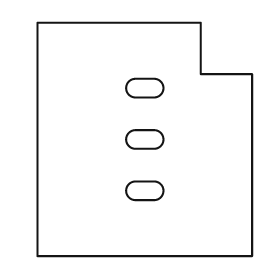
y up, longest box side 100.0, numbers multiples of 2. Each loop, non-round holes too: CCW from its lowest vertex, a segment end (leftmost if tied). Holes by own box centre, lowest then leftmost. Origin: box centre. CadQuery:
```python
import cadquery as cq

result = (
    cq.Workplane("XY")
    .moveTo(-46.0, -50.0)
    .lineTo(46.0, -50.0)
    .lineTo(46.0, 28.0)
    .lineTo(24.0, 28.0)
    .lineTo(24.0, 50.0)
    .lineTo(-46.0, 50.0)
    .close()
    .moveTo(-4.0, -26.0)
    .lineTo(4.0, -26.0)
    .threePointArc((8.0, -22.0), (4.0, -18.0))
    .lineTo(-4.0, -18.0)
    .threePointArc((-8.0, -22.0), (-4.0, -26.0))
    .close()
    .moveTo(-4.0, -4.0)
    .lineTo(4.0, -4.0)
    .threePointArc((8.0, 0.0), (4.0, 4.0))
    .lineTo(-4.0, 4.0)
    .threePointArc((-8.0, 0.0), (-4.0, -4.0))
    .close()
    .moveTo(-4.0, 18.0)
    .lineTo(4.0, 18.0)
    .threePointArc((8.0, 22.0), (4.0, 26.0))
    .lineTo(-4.0, 26.0)
    .threePointArc((-8.0, 22.0), (-4.0, 18.0))
    .close()
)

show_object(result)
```